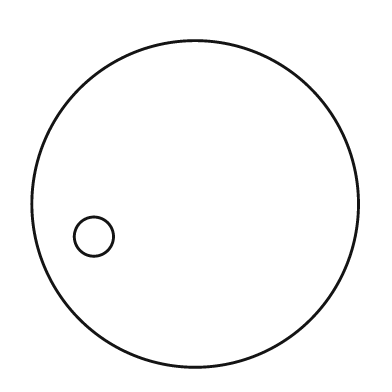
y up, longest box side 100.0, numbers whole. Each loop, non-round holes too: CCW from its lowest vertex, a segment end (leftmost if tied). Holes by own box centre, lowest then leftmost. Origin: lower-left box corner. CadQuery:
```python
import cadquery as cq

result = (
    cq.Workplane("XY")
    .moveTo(50.0, 50.0)
    .circle(50.0)
    .moveTo(19.0, 40.0)
    .circle(6.0)
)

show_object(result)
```